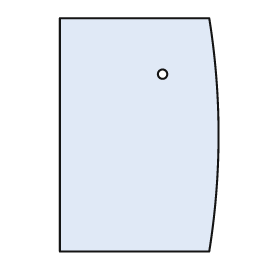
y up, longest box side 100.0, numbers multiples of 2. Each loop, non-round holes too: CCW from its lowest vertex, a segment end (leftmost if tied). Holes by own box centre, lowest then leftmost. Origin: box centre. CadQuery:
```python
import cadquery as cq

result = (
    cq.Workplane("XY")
    .moveTo(-34.0, -50.0)
    .lineTo(30.0, -50.0)
    .threePointArc((34.0, 0.0), (30.0, 50.0))
    .lineTo(-34.0, 50.0)
    .close()
    .moveTo(10.0, 26.0)
    .circle(2.0)
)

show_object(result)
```